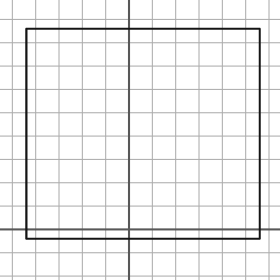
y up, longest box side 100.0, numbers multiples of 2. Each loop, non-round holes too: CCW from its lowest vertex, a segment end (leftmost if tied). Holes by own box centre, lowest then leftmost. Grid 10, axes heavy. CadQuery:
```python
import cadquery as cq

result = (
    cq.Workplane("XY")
    .moveTo(-44.0, -4.0)
    .lineTo(56.0, -4.0)
    .lineTo(56.0, 86.0)
    .lineTo(-44.0, 86.0)
    .close()
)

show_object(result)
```